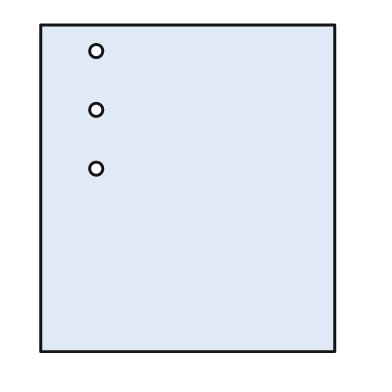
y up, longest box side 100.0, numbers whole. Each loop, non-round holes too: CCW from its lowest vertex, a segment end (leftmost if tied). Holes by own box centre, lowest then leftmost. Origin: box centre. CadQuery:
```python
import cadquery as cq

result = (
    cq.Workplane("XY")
    .moveTo(-45.0, -50.0)
    .lineTo(45.0, -50.0)
    .lineTo(45.0, 50.0)
    .lineTo(-45.0, 50.0)
    .close()
    .moveTo(-28.0, 6.0)
    .circle(2.0)
    .moveTo(-28.0, 24.0)
    .circle(2.0)
    .moveTo(-28.0, 42.0)
    .circle(2.0)
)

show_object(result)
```